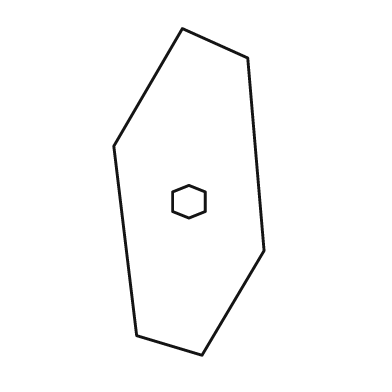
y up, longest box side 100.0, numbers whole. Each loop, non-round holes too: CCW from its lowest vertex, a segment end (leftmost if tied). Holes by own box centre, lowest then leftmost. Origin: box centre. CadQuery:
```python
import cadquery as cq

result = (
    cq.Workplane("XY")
    .moveTo(4.0, -50.0)
    .lineTo(23.0, -18.0)
    .lineTo(18.0, 41.0)
    .lineTo(-2.0, 50.0)
    .lineTo(-23.0, 14.0)
    .lineTo(-16.0, -44.0)
    .close()
    .moveTo(0.0, -8.0)
    .lineTo(5.0, -6.0)
    .lineTo(5.0, 0.0)
    .lineTo(0.0, 2.0)
    .lineTo(-5.0, 0.0)
    .lineTo(-5.0, -6.0)
    .close()
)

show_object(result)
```